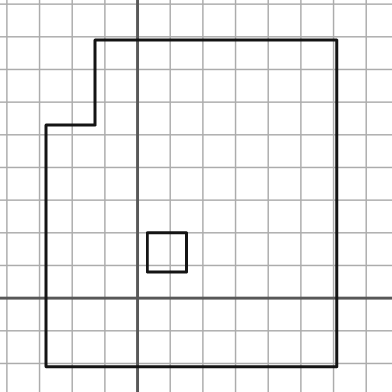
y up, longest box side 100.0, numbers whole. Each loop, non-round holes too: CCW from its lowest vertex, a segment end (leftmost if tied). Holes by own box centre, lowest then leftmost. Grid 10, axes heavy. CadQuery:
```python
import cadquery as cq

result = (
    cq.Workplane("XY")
    .moveTo(-28.0, -21.0)
    .lineTo(61.0, -21.0)
    .lineTo(61.0, 79.0)
    .lineTo(-13.0, 79.0)
    .lineTo(-13.0, 53.0)
    .lineTo(-28.0, 53.0)
    .close()
    .moveTo(3.0, 8.0)
    .lineTo(15.0, 8.0)
    .lineTo(15.0, 20.0)
    .lineTo(3.0, 20.0)
    .close()
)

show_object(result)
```